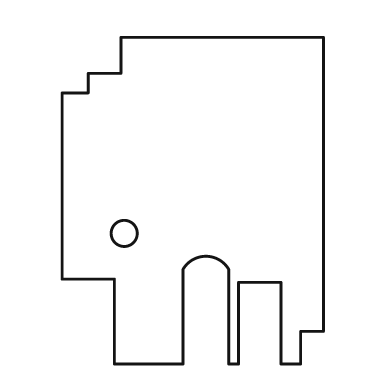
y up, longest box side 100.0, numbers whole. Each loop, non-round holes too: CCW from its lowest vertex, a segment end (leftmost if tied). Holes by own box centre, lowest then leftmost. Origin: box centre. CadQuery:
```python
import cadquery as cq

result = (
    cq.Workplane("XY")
    .moveTo(-24.0, -50.0)
    .lineTo(-3.0, -50.0)
    .lineTo(-3.0, -21.0)
    .threePointArc((4.0, -17.0), (11.0, -21.0))
    .lineTo(11.0, -50.0)
    .lineTo(14.0, -50.0)
    .lineTo(14.0, -25.0)
    .lineTo(27.0, -25.0)
    .lineTo(27.0, -50.0)
    .lineTo(33.0, -50.0)
    .lineTo(33.0, -40.0)
    .lineTo(40.0, -40.0)
    .lineTo(40.0, 50.0)
    .lineTo(-22.0, 50.0)
    .lineTo(-22.0, 39.0)
    .lineTo(-32.0, 39.0)
    .lineTo(-32.0, 33.0)
    .lineTo(-40.0, 33.0)
    .lineTo(-40.0, -24.0)
    .lineTo(-24.0, -24.0)
    .close()
    .moveTo(-21.0, -10.0)
    .circle(4.0)
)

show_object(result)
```